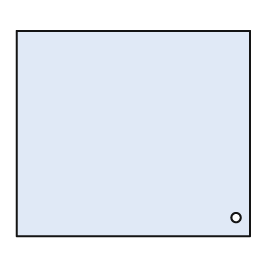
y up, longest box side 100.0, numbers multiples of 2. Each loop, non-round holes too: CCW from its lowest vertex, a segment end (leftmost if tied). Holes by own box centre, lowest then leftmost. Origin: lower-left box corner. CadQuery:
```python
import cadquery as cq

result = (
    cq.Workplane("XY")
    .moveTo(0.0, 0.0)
    .lineTo(100.0, 0.0)
    .lineTo(100.0, 88.0)
    .lineTo(0.0, 88.0)
    .close()
    .moveTo(94.0, 8.0)
    .circle(2.0)
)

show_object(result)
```